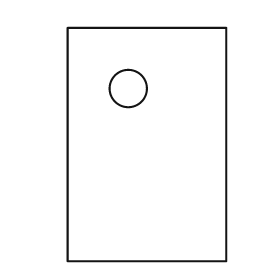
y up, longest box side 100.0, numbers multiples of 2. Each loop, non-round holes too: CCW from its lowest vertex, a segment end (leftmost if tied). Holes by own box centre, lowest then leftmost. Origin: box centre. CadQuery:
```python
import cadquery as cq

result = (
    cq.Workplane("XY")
    .moveTo(-34.0, -50.0)
    .lineTo(34.0, -50.0)
    .lineTo(34.0, 50.0)
    .lineTo(-34.0, 50.0)
    .close()
    .moveTo(-8.0, 24.0)
    .circle(8.0)
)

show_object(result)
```